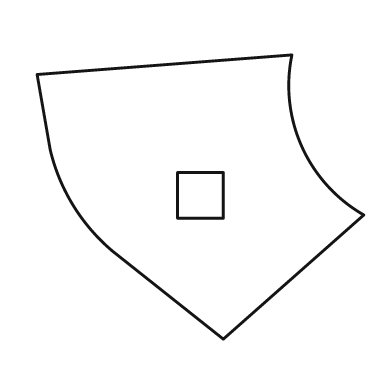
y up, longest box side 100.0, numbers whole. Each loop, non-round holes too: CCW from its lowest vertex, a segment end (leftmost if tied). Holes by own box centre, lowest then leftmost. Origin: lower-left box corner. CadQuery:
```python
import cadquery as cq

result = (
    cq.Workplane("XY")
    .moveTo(57.0, 0.0)
    .lineTo(100.0, 38.0)
    .threePointArc((81.0, 59.0), (78.0, 87.0))
    .lineTo(0.0, 81.0)
    .lineTo(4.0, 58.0)
    .threePointArc((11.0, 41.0), (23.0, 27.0))
    .close()
    .moveTo(43.0, 37.0)
    .lineTo(57.0, 37.0)
    .lineTo(57.0, 51.0)
    .lineTo(43.0, 51.0)
    .close()
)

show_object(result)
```